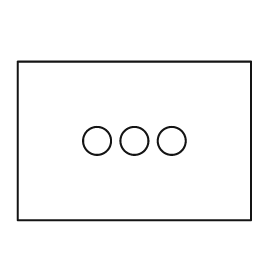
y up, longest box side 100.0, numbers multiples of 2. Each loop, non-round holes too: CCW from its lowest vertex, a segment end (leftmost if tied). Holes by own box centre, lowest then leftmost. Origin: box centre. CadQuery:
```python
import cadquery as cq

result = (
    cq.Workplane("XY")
    .moveTo(-50.0, -34.0)
    .lineTo(50.0, -34.0)
    .lineTo(50.0, 34.0)
    .lineTo(-50.0, 34.0)
    .close()
    .moveTo(-16.0, 0.0)
    .circle(6.0)
    .moveTo(0.0, 0.0)
    .circle(6.0)
    .moveTo(16.0, 0.0)
    .circle(6.0)
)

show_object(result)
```